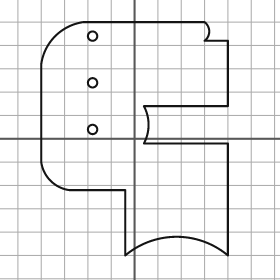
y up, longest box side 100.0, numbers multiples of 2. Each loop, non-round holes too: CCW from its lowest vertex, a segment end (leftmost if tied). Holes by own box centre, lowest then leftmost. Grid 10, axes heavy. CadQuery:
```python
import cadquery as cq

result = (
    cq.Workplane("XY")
    .moveTo(-4.0, -50.0)
    .threePointArc((18.0, -42.0), (40.0, -50.0))
    .lineTo(40.0, -2.0)
    .lineTo(4.0, -2.0)
    .threePointArc((6.0, 6.0), (4.0, 14.0))
    .lineTo(40.0, 14.0)
    .lineTo(40.0, 42.0)
    .lineTo(30.0, 42.0)
    .threePointArc((32.0, 46.0), (30.0, 50.0))
    .lineTo(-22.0, 50.0)
    .threePointArc((-34.0, 44.0), (-40.0, 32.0))
    .lineTo(-40.0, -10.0)
    .threePointArc((-36.0, -18.0), (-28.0, -22.0))
    .lineTo(-4.0, -22.0)
    .close()
    .moveTo(-18.0, 4.0)
    .circle(2.0)
    .moveTo(-18.0, 24.0)
    .circle(2.0)
    .moveTo(-18.0, 44.0)
    .circle(2.0)
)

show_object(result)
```